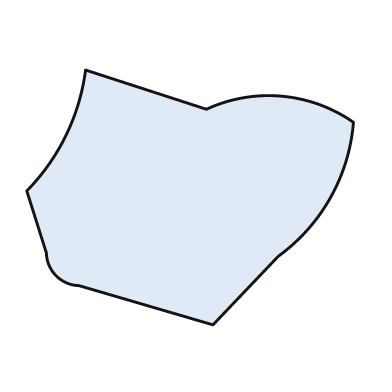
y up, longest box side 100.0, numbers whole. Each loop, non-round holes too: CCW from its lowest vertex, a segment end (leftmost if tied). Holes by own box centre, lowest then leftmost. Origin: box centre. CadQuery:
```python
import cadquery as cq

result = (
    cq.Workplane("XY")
    .moveTo(7.0, -39.0)
    .lineTo(27.0, -18.0)
    .threePointArc((43.0, 0.0), (50.0, 23.0))
    .threePointArc((28.0, 31.0), (5.0, 27.0))
    .lineTo(-32.0, 39.0)
    .threePointArc((-38.0, 19.0), (-50.0, 2.0))
    .lineTo(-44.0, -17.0)
    .threePointArc((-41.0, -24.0), (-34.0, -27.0))
    .close()
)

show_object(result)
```